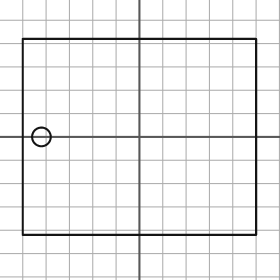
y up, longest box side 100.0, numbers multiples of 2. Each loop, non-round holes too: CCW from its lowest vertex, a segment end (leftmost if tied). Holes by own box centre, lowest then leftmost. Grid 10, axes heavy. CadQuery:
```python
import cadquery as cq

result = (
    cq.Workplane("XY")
    .moveTo(-50.0, -42.0)
    .lineTo(50.0, -42.0)
    .lineTo(50.0, 42.0)
    .lineTo(-50.0, 42.0)
    .close()
    .moveTo(-42.0, 0.0)
    .circle(4.0)
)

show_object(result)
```